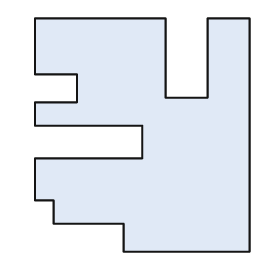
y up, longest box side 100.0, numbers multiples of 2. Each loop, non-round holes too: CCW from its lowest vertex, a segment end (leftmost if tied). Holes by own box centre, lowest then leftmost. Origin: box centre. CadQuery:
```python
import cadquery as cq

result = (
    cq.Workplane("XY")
    .moveTo(-8.0, -50.0)
    .lineTo(46.0, -50.0)
    .lineTo(46.0, 50.0)
    .lineTo(28.0, 50.0)
    .lineTo(28.0, 16.0)
    .lineTo(10.0, 16.0)
    .lineTo(10.0, 50.0)
    .lineTo(-46.0, 50.0)
    .lineTo(-46.0, 26.0)
    .lineTo(-28.0, 26.0)
    .lineTo(-28.0, 14.0)
    .lineTo(-46.0, 14.0)
    .lineTo(-46.0, 4.0)
    .lineTo(0.0, 4.0)
    .lineTo(0.0, -10.0)
    .lineTo(-46.0, -10.0)
    .lineTo(-46.0, -28.0)
    .lineTo(-38.0, -28.0)
    .lineTo(-38.0, -38.0)
    .lineTo(-8.0, -38.0)
    .close()
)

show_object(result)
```